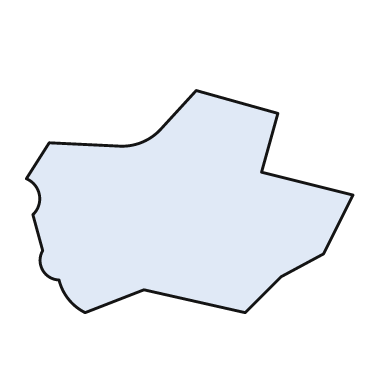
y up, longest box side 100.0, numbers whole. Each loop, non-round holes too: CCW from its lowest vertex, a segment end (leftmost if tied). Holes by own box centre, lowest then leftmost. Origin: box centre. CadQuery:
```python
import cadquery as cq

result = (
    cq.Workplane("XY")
    .moveTo(-32.0, -34.0)
    .lineTo(-14.0, -27.0)
    .lineTo(17.0, -34.0)
    .lineTo(28.0, -23.0)
    .lineTo(41.0, -16.0)
    .lineTo(50.0, 2.0)
    .lineTo(22.0, 9.0)
    .lineTo(27.0, 27.0)
    .lineTo(2.0, 34.0)
    .lineTo(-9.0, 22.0)
    .threePointArc((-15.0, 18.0), (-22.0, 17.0))
    .lineTo(-43.0, 18.0)
    .lineTo(-50.0, 7.0)
    .threePointArc((-46.0, 2.0), (-48.0, -4.0))
    .lineTo(-45.0, -15.0)
    .threePointArc((-45.0, -21.0), (-40.0, -24.0))
    .threePointArc((-37.0, -30.0), (-32.0, -34.0))
    .close()
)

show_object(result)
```